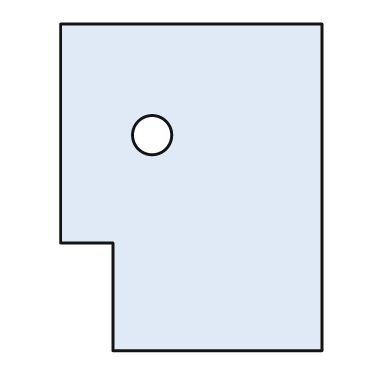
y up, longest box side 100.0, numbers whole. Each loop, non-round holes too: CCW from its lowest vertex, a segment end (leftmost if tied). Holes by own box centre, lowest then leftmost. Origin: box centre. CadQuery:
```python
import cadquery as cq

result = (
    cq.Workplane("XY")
    .moveTo(-24.0, -50.0)
    .lineTo(40.0, -50.0)
    .lineTo(40.0, 50.0)
    .lineTo(-40.0, 50.0)
    .lineTo(-40.0, -17.0)
    .lineTo(-24.0, -17.0)
    .close()
    .moveTo(-12.0, 16.0)
    .circle(6.0)
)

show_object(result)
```